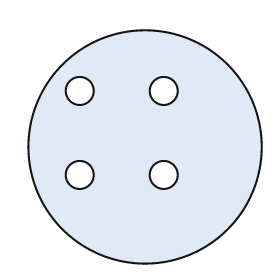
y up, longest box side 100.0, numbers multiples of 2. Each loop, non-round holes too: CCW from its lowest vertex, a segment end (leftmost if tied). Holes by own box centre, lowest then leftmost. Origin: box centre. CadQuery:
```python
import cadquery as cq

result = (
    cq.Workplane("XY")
    .moveTo(0.0, 0.0)
    .circle(50.0)
    .moveTo(-28.0, -12.0)
    .circle(6.0)
    .moveTo(8.0, -12.0)
    .circle(6.0)
    .moveTo(-28.0, 24.0)
    .circle(6.0)
    .moveTo(8.0, 24.0)
    .circle(6.0)
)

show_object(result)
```